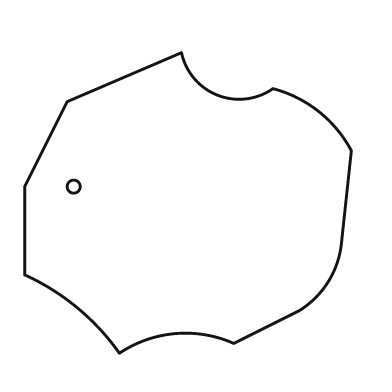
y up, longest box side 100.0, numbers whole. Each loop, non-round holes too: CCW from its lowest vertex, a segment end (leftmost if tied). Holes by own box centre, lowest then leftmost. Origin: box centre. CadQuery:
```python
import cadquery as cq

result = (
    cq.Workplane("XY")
    .moveTo(-21.0, -46.0)
    .threePointArc((-4.0, -40.0), (14.0, -43.0))
    .lineTo(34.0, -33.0)
    .threePointArc((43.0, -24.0), (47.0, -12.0))
    .lineTo(50.0, 16.0)
    .threePointArc((40.0, 28.0), (26.0, 35.0))
    .threePointArc((9.0, 33.0), (-2.0, 46.0))
    .lineTo(-37.0, 31.0)
    .lineTo(-50.0, 5.0)
    .lineTo(-50.0, -22.0)
    .threePointArc((-34.0, -32.0), (-21.0, -46.0))
    .close()
    .moveTo(-35.0, 5.0)
    .circle(2.0)
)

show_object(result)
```